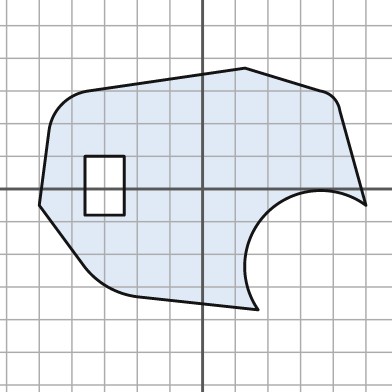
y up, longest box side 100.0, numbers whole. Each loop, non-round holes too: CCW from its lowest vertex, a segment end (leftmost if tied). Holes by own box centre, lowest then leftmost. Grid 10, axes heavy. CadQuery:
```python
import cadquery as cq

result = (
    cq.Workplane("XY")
    .moveTo(17.0, -37.0)
    .threePointArc((20.0, -7.0), (50.0, -5.0))
    .lineTo(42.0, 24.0)
    .threePointArc((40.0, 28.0), (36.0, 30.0))
    .lineTo(13.0, 37.0)
    .lineTo(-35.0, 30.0)
    .threePointArc((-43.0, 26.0), (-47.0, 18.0))
    .lineTo(-50.0, -5.0)
    .lineTo(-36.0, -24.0)
    .threePointArc((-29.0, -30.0), (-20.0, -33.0))
    .close()
    .moveTo(-36.0, -8.0)
    .lineTo(-24.0, -8.0)
    .lineTo(-24.0, 10.0)
    .lineTo(-36.0, 10.0)
    .close()
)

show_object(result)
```